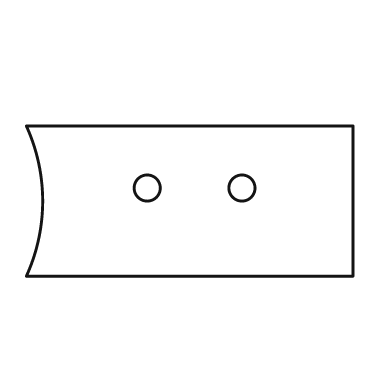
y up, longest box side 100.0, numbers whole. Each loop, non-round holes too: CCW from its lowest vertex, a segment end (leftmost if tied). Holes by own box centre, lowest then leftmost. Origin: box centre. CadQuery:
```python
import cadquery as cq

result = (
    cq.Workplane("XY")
    .moveTo(-50.0, -23.0)
    .lineTo(50.0, -23.0)
    .lineTo(50.0, 23.0)
    .lineTo(-50.0, 23.0)
    .threePointArc((-45.0, 0.0), (-50.0, -23.0))
    .close()
    .moveTo(-13.0, 4.0)
    .circle(4.0)
    .moveTo(16.0, 4.0)
    .circle(4.0)
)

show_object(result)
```